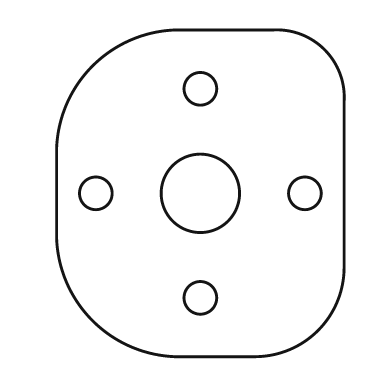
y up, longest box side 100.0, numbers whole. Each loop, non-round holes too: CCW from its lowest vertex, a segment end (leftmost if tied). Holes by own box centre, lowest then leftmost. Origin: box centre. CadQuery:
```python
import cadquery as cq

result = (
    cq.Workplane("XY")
    .moveTo(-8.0, -50.0)
    .lineTo(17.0, -50.0)
    .threePointArc((36.0, -42.0), (44.0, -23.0))
    .lineTo(44.0, 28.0)
    .threePointArc((38.0, 44.0), (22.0, 50.0))
    .lineTo(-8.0, 50.0)
    .threePointArc((-33.0, 39.0), (-44.0, 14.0))
    .lineTo(-44.0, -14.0)
    .threePointArc((-33.0, -39.0), (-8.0, -50.0))
    .close()
    .moveTo(0.0, -32.0)
    .circle(5.0)
    .moveTo(-32.0, 0.0)
    .circle(5.0)
    .moveTo(0.0, 0.0)
    .circle(12.0)
    .moveTo(32.0, 0.0)
    .circle(5.0)
    .moveTo(0.0, 32.0)
    .circle(5.0)
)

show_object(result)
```